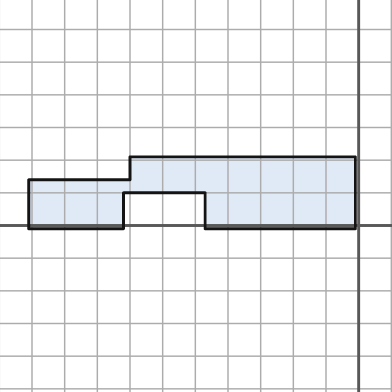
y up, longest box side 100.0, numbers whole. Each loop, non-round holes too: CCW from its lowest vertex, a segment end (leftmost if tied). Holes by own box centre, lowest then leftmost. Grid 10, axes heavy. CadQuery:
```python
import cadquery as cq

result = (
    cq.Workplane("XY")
    .moveTo(-101.0, -1.0)
    .lineTo(-72.0, -1.0)
    .lineTo(-72.0, 10.0)
    .lineTo(-47.0, 10.0)
    .lineTo(-47.0, -1.0)
    .lineTo(-1.0, -1.0)
    .lineTo(-1.0, 21.0)
    .lineTo(-70.0, 21.0)
    .lineTo(-70.0, 14.0)
    .lineTo(-101.0, 14.0)
    .close()
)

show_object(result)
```